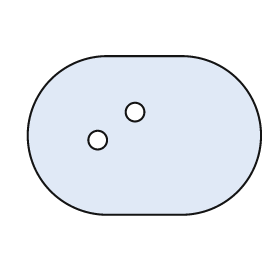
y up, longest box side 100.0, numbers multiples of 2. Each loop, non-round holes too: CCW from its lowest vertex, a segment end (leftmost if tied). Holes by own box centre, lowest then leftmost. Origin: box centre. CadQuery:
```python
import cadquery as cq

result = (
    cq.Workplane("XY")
    .moveTo(-16.0, -34.0)
    .lineTo(16.0, -34.0)
    .threePointArc((50.0, 0.0), (16.0, 34.0))
    .lineTo(-16.0, 34.0)
    .threePointArc((-50.0, 0.0), (-16.0, -34.0))
    .close()
    .moveTo(-20.0, -2.0)
    .circle(4.0)
    .moveTo(-4.0, 10.0)
    .circle(4.0)
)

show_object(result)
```